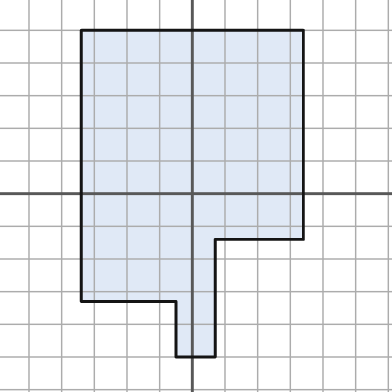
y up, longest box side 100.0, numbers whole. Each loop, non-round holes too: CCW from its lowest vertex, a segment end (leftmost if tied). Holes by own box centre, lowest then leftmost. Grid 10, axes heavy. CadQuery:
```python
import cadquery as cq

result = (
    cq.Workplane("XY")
    .moveTo(-5.0, -50.0)
    .lineTo(7.0, -50.0)
    .lineTo(7.0, -14.0)
    .lineTo(34.0, -14.0)
    .lineTo(34.0, 50.0)
    .lineTo(-34.0, 50.0)
    .lineTo(-34.0, -33.0)
    .lineTo(-5.0, -33.0)
    .close()
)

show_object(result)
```